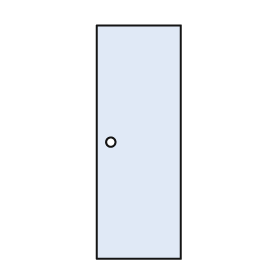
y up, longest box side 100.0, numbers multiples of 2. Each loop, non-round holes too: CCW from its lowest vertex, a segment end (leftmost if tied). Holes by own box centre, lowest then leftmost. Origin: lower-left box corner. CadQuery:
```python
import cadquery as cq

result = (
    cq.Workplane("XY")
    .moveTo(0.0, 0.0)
    .lineTo(36.0, 0.0)
    .lineTo(36.0, 100.0)
    .lineTo(0.0, 100.0)
    .close()
    .moveTo(6.0, 50.0)
    .circle(2.0)
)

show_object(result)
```